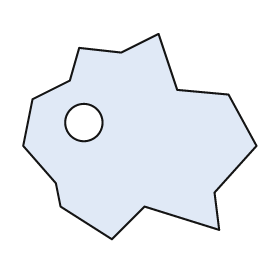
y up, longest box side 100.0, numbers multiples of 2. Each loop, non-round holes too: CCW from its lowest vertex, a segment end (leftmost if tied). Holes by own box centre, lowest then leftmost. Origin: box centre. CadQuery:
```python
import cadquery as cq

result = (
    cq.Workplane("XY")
    .moveTo(-12.0, -44.0)
    .lineTo(2.0, -30.0)
    .lineTo(34.0, -40.0)
    .lineTo(32.0, -24.0)
    .lineTo(50.0, -4.0)
    .lineTo(38.0, 18.0)
    .lineTo(16.0, 20.0)
    .lineTo(8.0, 44.0)
    .lineTo(-8.0, 36.0)
    .lineTo(-26.0, 38.0)
    .lineTo(-30.0, 24.0)
    .lineTo(-46.0, 16.0)
    .lineTo(-50.0, -4.0)
    .lineTo(-36.0, -20.0)
    .lineTo(-34.0, -30.0)
    .close()
    .moveTo(-24.0, 6.0)
    .circle(8.0)
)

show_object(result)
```